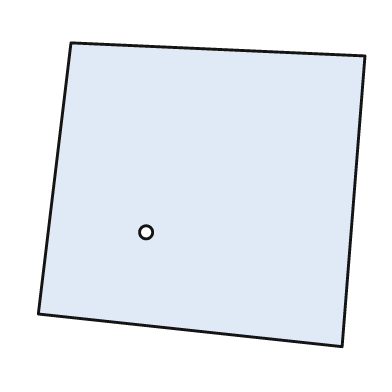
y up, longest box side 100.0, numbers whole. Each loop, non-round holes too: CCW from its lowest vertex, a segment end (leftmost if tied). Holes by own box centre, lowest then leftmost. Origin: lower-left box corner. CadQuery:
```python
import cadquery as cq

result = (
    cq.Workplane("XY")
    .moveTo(93.0, 0.0)
    .lineTo(100.0, 89.0)
    .lineTo(10.0, 93.0)
    .lineTo(0.0, 10.0)
    .close()
    .moveTo(33.0, 35.0)
    .circle(2.0)
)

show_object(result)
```